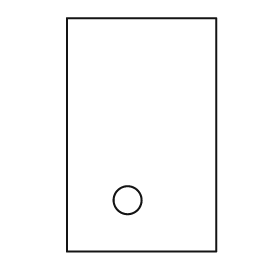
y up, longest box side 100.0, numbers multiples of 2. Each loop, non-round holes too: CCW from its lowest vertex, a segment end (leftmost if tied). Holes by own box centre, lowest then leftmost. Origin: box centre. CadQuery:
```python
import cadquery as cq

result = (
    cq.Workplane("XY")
    .moveTo(-32.0, -50.0)
    .lineTo(32.0, -50.0)
    .lineTo(32.0, 50.0)
    .lineTo(-32.0, 50.0)
    .close()
    .moveTo(-6.0, -28.0)
    .circle(6.0)
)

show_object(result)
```